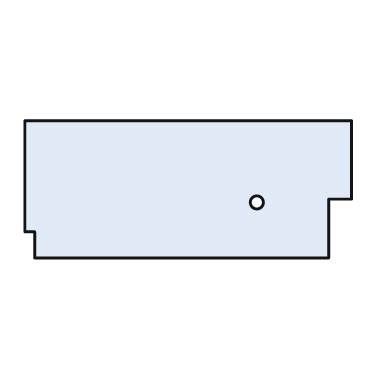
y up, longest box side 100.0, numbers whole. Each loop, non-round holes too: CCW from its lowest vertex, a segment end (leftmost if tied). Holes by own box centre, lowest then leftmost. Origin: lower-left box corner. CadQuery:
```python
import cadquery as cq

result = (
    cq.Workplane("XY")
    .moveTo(3.0, 0.0)
    .lineTo(93.0, 0.0)
    .lineTo(93.0, 18.0)
    .lineTo(100.0, 18.0)
    .lineTo(100.0, 42.0)
    .lineTo(0.0, 42.0)
    .lineTo(0.0, 8.0)
    .lineTo(3.0, 8.0)
    .close()
    .moveTo(71.0, 17.0)
    .circle(2.0)
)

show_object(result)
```